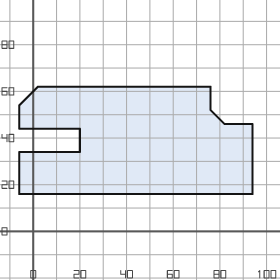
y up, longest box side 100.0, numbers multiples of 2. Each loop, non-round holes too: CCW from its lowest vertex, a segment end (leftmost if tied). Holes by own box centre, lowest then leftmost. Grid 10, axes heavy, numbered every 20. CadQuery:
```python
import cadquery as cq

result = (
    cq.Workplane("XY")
    .moveTo(-6.0, 16.0)
    .lineTo(94.0, 16.0)
    .lineTo(94.0, 46.0)
    .lineTo(82.0, 46.0)
    .lineTo(76.0, 52.0)
    .lineTo(76.0, 62.0)
    .lineTo(2.0, 62.0)
    .lineTo(-6.0, 54.0)
    .lineTo(-6.0, 44.0)
    .lineTo(20.0, 44.0)
    .lineTo(20.0, 34.0)
    .lineTo(-6.0, 34.0)
    .close()
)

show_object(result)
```